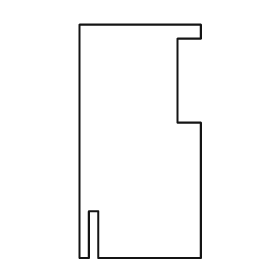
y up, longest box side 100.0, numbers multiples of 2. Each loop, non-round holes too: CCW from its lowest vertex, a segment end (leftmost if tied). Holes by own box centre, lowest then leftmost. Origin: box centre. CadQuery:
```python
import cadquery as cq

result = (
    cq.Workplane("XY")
    .moveTo(-26.0, -50.0)
    .lineTo(-22.0, -50.0)
    .lineTo(-22.0, -30.0)
    .lineTo(-18.0, -30.0)
    .lineTo(-18.0, -50.0)
    .lineTo(26.0, -50.0)
    .lineTo(26.0, 8.0)
    .lineTo(16.0, 8.0)
    .lineTo(16.0, 44.0)
    .lineTo(26.0, 44.0)
    .lineTo(26.0, 50.0)
    .lineTo(-26.0, 50.0)
    .close()
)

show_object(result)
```